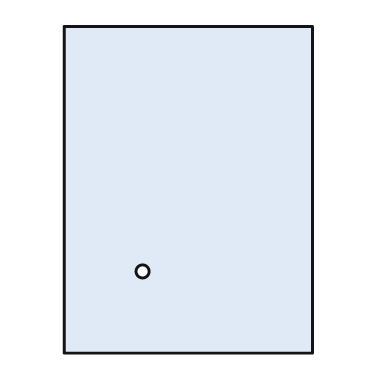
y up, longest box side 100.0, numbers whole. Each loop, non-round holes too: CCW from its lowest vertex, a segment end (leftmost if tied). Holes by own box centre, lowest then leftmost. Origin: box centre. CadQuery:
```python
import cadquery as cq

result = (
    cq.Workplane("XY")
    .moveTo(-38.0, -50.0)
    .lineTo(38.0, -50.0)
    .lineTo(38.0, 50.0)
    .lineTo(-38.0, 50.0)
    .close()
    .moveTo(-14.0, -25.0)
    .circle(2.0)
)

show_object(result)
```